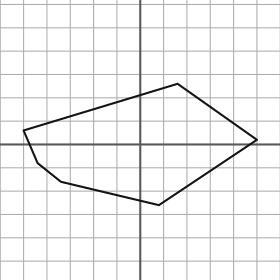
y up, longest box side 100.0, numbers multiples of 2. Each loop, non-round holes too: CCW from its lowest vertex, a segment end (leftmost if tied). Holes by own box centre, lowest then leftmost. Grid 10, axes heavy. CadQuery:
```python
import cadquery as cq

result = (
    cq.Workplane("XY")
    .moveTo(8.0, -26.0)
    .lineTo(50.0, 2.0)
    .lineTo(16.0, 26.0)
    .lineTo(-50.0, 6.0)
    .lineTo(-44.0, -8.0)
    .lineTo(-34.0, -16.0)
    .close()
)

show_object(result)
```